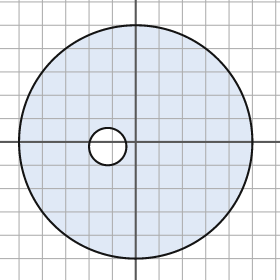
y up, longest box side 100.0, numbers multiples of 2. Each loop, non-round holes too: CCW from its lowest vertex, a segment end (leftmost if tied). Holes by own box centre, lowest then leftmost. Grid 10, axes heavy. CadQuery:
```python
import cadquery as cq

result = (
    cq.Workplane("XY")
    .moveTo(0.0, 0.0)
    .circle(50.0)
    .moveTo(-12.0, -2.0)
    .circle(8.0)
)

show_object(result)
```